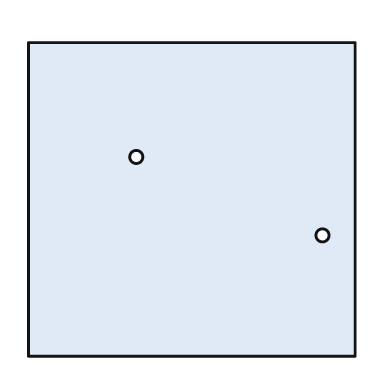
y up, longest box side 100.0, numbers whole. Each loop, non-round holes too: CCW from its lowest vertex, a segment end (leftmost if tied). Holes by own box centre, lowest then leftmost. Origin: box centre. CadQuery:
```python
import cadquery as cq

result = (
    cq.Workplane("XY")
    .moveTo(-50.0, -48.0)
    .lineTo(50.0, -48.0)
    .lineTo(50.0, 48.0)
    .lineTo(-50.0, 48.0)
    .close()
    .moveTo(40.0, -11.0)
    .circle(2.0)
    .moveTo(-17.0, 13.0)
    .circle(2.0)
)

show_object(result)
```